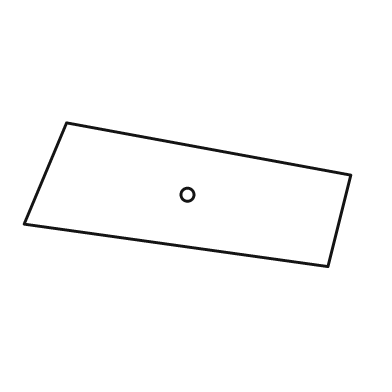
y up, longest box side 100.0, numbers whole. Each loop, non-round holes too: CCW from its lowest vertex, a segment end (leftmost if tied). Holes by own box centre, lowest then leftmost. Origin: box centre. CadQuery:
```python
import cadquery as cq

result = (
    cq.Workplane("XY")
    .moveTo(43.0, -22.0)
    .lineTo(50.0, 6.0)
    .lineTo(-37.0, 22.0)
    .lineTo(-50.0, -9.0)
    .close()
    .moveTo(0.0, 0.0)
    .circle(2.0)
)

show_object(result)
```